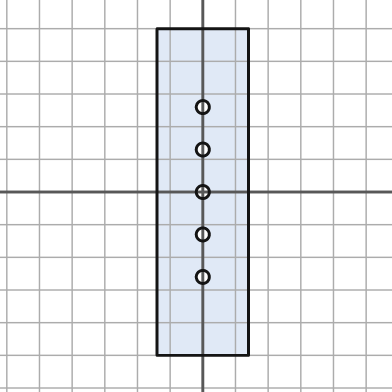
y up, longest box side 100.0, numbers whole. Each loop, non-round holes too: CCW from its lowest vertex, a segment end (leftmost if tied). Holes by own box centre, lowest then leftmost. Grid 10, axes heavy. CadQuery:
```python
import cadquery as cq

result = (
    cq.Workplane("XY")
    .moveTo(-14.0, -50.0)
    .lineTo(14.0, -50.0)
    .lineTo(14.0, 50.0)
    .lineTo(-14.0, 50.0)
    .close()
    .moveTo(0.0, -26.0)
    .circle(2.0)
    .moveTo(0.0, -13.0)
    .circle(2.0)
    .moveTo(0.0, 0.0)
    .circle(2.0)
    .moveTo(0.0, 13.0)
    .circle(2.0)
    .moveTo(0.0, 26.0)
    .circle(2.0)
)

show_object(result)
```